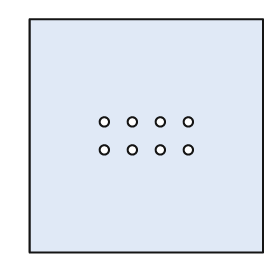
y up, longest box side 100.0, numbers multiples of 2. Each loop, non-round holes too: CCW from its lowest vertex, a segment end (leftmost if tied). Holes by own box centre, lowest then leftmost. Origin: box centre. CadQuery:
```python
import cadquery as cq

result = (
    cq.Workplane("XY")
    .moveTo(-50.0, -50.0)
    .lineTo(50.0, -50.0)
    .lineTo(50.0, 50.0)
    .lineTo(-50.0, 50.0)
    .close()
    .moveTo(-18.0, -6.0)
    .circle(2.0)
    .moveTo(-6.0, -6.0)
    .circle(2.0)
    .moveTo(6.0, -6.0)
    .circle(2.0)
    .moveTo(18.0, -6.0)
    .circle(2.0)
    .moveTo(-18.0, 6.0)
    .circle(2.0)
    .moveTo(-6.0, 6.0)
    .circle(2.0)
    .moveTo(6.0, 6.0)
    .circle(2.0)
    .moveTo(18.0, 6.0)
    .circle(2.0)
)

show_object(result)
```